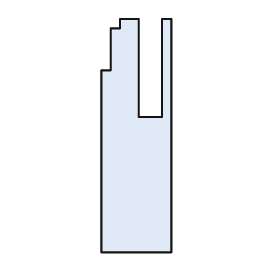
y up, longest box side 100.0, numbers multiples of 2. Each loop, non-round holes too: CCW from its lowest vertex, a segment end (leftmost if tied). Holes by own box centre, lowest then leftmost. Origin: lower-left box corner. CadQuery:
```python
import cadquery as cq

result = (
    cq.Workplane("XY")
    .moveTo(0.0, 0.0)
    .lineTo(30.0, 0.0)
    .lineTo(30.0, 100.0)
    .lineTo(26.0, 100.0)
    .lineTo(26.0, 58.0)
    .lineTo(16.0, 58.0)
    .lineTo(16.0, 100.0)
    .lineTo(8.0, 100.0)
    .lineTo(8.0, 96.0)
    .lineTo(4.0, 96.0)
    .lineTo(4.0, 78.0)
    .lineTo(0.0, 78.0)
    .close()
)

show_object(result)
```